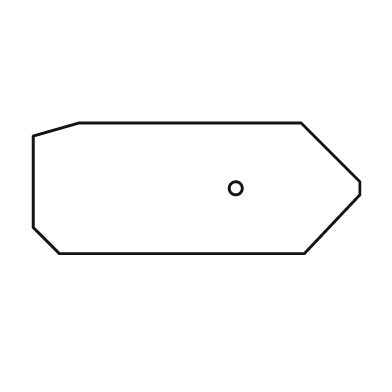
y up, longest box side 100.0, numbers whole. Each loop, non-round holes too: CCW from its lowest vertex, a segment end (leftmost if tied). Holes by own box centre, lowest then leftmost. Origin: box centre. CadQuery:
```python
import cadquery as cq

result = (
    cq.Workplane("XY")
    .moveTo(-42.0, -20.0)
    .lineTo(33.0, -20.0)
    .lineTo(50.0, -2.0)
    .lineTo(50.0, 2.0)
    .lineTo(32.0, 20.0)
    .lineTo(-36.0, 20.0)
    .lineTo(-50.0, 16.0)
    .lineTo(-50.0, -12.0)
    .close()
    .moveTo(12.0, 0.0)
    .circle(2.0)
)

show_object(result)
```